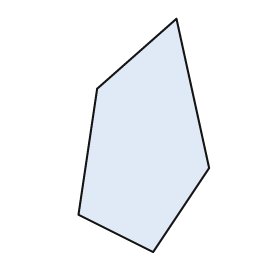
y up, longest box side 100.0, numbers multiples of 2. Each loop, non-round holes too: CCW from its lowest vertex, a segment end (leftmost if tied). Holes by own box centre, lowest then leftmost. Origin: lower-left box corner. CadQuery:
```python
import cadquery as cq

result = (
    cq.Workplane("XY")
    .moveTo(32.0, 0.0)
    .lineTo(56.0, 36.0)
    .lineTo(42.0, 100.0)
    .lineTo(8.0, 70.0)
    .lineTo(0.0, 16.0)
    .close()
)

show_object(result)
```